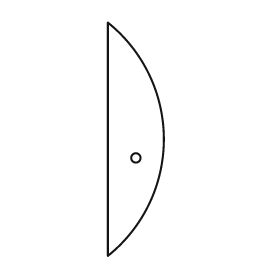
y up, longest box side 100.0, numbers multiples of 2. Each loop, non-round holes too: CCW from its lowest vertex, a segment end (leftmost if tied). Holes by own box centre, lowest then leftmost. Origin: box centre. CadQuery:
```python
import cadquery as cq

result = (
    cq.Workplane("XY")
    .moveTo(-12.0, -50.0)
    .threePointArc((12.0, 0.0), (-12.0, 50.0))
    .close()
    .moveTo(0.0, -8.0)
    .circle(2.0)
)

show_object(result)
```